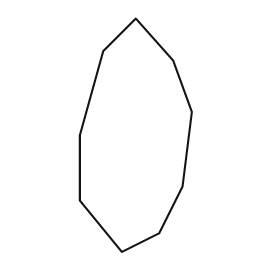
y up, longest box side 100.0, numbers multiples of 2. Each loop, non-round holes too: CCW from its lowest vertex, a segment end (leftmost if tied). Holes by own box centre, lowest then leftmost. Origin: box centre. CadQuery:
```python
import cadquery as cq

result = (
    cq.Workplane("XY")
    .moveTo(-6.0, -50.0)
    .lineTo(10.0, -42.0)
    .lineTo(20.0, -22.0)
    .lineTo(24.0, 10.0)
    .lineTo(16.0, 32.0)
    .lineTo(0.0, 50.0)
    .lineTo(-14.0, 36.0)
    .lineTo(-24.0, 0.0)
    .lineTo(-24.0, -28.0)
    .close()
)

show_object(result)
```